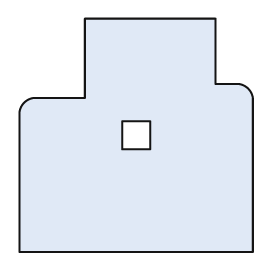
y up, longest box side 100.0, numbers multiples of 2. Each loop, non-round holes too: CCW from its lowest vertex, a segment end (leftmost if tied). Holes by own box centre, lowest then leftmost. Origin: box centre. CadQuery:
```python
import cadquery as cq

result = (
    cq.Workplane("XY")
    .moveTo(-50.0, -50.0)
    .lineTo(50.0, -50.0)
    .lineTo(50.0, 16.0)
    .threePointArc((48.0, 20.0), (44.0, 22.0))
    .lineTo(34.0, 22.0)
    .lineTo(34.0, 50.0)
    .lineTo(-22.0, 50.0)
    .lineTo(-22.0, 16.0)
    .lineTo(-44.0, 16.0)
    .threePointArc((-48.0, 14.0), (-50.0, 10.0))
    .close()
    .moveTo(-6.0, -6.0)
    .lineTo(6.0, -6.0)
    .lineTo(6.0, 6.0)
    .lineTo(-6.0, 6.0)
    .close()
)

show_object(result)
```